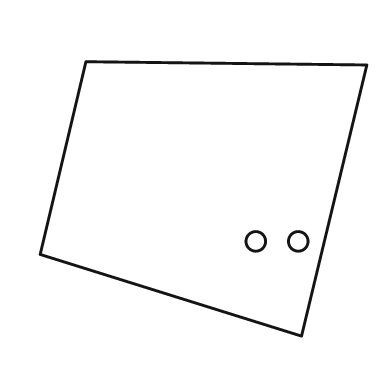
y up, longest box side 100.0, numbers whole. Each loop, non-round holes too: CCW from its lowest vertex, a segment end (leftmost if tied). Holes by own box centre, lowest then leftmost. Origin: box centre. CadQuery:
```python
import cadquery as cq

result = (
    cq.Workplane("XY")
    .moveTo(30.0, -42.0)
    .lineTo(50.0, 41.0)
    .lineTo(-36.0, 42.0)
    .lineTo(-50.0, -17.0)
    .close()
    .moveTo(16.0, -13.0)
    .circle(3.0)
    .moveTo(29.0, -13.0)
    .circle(3.0)
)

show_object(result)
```